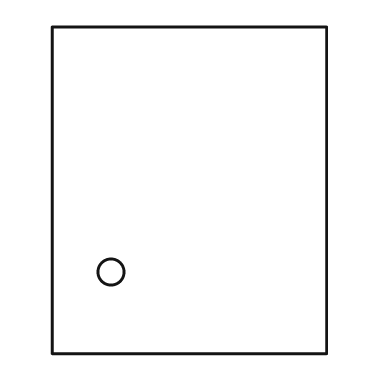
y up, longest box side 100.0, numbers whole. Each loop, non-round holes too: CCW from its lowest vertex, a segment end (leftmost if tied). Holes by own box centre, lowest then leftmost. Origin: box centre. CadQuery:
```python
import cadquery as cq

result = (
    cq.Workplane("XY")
    .moveTo(-42.0, -50.0)
    .lineTo(42.0, -50.0)
    .lineTo(42.0, 50.0)
    .lineTo(-42.0, 50.0)
    .close()
    .moveTo(-24.0, -25.0)
    .circle(4.0)
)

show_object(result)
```